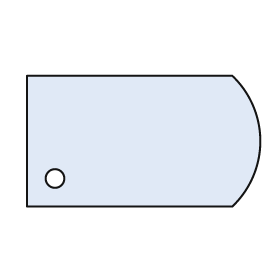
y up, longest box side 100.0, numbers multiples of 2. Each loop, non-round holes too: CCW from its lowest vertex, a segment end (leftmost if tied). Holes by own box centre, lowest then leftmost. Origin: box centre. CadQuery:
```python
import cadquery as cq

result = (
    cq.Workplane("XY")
    .moveTo(-50.0, -28.0)
    .lineTo(38.0, -28.0)
    .threePointArc((50.0, 0.0), (38.0, 28.0))
    .lineTo(-50.0, 28.0)
    .close()
    .moveTo(-38.0, -16.0)
    .circle(4.0)
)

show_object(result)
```